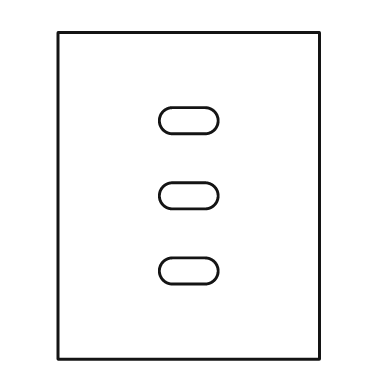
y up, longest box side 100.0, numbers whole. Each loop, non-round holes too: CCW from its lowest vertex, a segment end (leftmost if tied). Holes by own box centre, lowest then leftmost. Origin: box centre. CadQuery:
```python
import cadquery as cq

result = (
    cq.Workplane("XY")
    .moveTo(-40.0, -50.0)
    .lineTo(40.0, -50.0)
    .lineTo(40.0, 50.0)
    .lineTo(-40.0, 50.0)
    .close()
    .moveTo(-5.0, -27.0)
    .lineTo(5.0, -27.0)
    .threePointArc((9.0, -23.0), (5.0, -19.0))
    .lineTo(-5.0, -19.0)
    .threePointArc((-9.0, -23.0), (-5.0, -27.0))
    .close()
    .moveTo(-5.0, -4.0)
    .lineTo(5.0, -4.0)
    .threePointArc((9.0, 0.0), (5.0, 4.0))
    .lineTo(-5.0, 4.0)
    .threePointArc((-9.0, 0.0), (-5.0, -4.0))
    .close()
    .moveTo(-5.0, 19.0)
    .lineTo(5.0, 19.0)
    .threePointArc((9.0, 23.0), (5.0, 27.0))
    .lineTo(-5.0, 27.0)
    .threePointArc((-9.0, 23.0), (-5.0, 19.0))
    .close()
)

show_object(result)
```